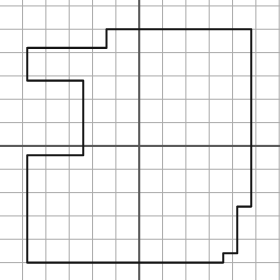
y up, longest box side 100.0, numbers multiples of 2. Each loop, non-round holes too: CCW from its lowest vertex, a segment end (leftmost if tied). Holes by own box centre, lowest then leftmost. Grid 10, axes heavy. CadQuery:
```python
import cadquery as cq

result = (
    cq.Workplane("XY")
    .moveTo(-48.0, -50.0)
    .lineTo(36.0, -50.0)
    .lineTo(36.0, -46.0)
    .lineTo(42.0, -46.0)
    .lineTo(42.0, -26.0)
    .lineTo(48.0, -26.0)
    .lineTo(48.0, 50.0)
    .lineTo(-14.0, 50.0)
    .lineTo(-14.0, 42.0)
    .lineTo(-48.0, 42.0)
    .lineTo(-48.0, 28.0)
    .lineTo(-24.0, 28.0)
    .lineTo(-24.0, -4.0)
    .lineTo(-48.0, -4.0)
    .close()
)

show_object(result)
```